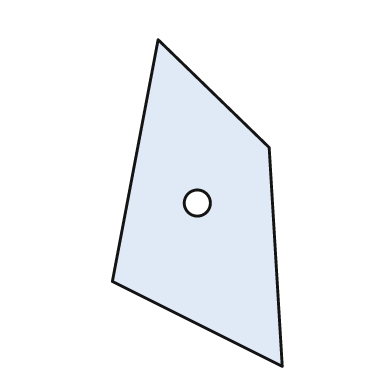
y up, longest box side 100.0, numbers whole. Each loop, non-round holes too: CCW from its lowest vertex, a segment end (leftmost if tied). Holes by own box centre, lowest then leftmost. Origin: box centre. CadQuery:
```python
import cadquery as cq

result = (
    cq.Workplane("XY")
    .moveTo(26.0, -50.0)
    .lineTo(22.0, 17.0)
    .lineTo(-12.0, 50.0)
    .lineTo(-26.0, -24.0)
    .close()
    .moveTo(0.0, 0.0)
    .circle(4.0)
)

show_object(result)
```